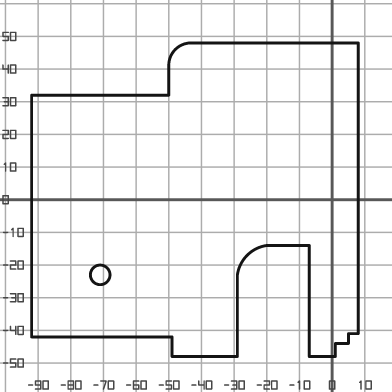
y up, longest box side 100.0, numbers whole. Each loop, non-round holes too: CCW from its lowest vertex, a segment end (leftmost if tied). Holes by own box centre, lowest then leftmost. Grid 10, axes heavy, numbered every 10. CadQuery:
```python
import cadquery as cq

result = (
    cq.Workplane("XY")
    .moveTo(-49.0, -48.0)
    .lineTo(-29.0, -48.0)
    .lineTo(-29.0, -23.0)
    .threePointArc((-26.0, -17.0), (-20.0, -14.0))
    .lineTo(-7.0, -14.0)
    .lineTo(-7.0, -48.0)
    .lineTo(1.0, -48.0)
    .lineTo(1.0, -44.0)
    .lineTo(5.0, -44.0)
    .lineTo(5.0, -41.0)
    .lineTo(8.0, -41.0)
    .lineTo(8.0, 48.0)
    .lineTo(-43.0, 48.0)
    .threePointArc((-48.0, 46.0), (-50.0, 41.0))
    .lineTo(-50.0, 32.0)
    .lineTo(-92.0, 32.0)
    .lineTo(-92.0, -42.0)
    .lineTo(-49.0, -42.0)
    .close()
    .moveTo(-71.0, -23.0)
    .circle(3.0)
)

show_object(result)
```